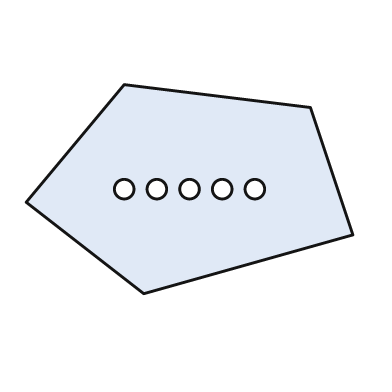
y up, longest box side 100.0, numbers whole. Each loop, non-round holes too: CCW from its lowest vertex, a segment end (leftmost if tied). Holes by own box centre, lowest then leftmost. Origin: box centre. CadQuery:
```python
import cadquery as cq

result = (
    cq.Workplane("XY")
    .moveTo(-14.0, -32.0)
    .lineTo(50.0, -14.0)
    .lineTo(37.0, 25.0)
    .lineTo(-20.0, 32.0)
    .lineTo(-50.0, -4.0)
    .close()
    .moveTo(-20.0, 0.0)
    .circle(3.0)
    .moveTo(-10.0, 0.0)
    .circle(3.0)
    .moveTo(0.0, 0.0)
    .circle(3.0)
    .moveTo(10.0, 0.0)
    .circle(3.0)
    .moveTo(20.0, 0.0)
    .circle(3.0)
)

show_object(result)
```